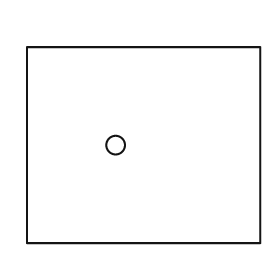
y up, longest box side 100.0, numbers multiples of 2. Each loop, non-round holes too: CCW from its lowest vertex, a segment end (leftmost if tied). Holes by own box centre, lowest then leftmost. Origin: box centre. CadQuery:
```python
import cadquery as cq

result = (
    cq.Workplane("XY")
    .moveTo(-50.0, -42.0)
    .lineTo(50.0, -42.0)
    .lineTo(50.0, 42.0)
    .lineTo(-50.0, 42.0)
    .close()
    .moveTo(-12.0, 0.0)
    .circle(4.0)
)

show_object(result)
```